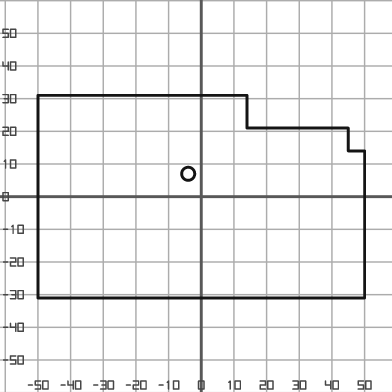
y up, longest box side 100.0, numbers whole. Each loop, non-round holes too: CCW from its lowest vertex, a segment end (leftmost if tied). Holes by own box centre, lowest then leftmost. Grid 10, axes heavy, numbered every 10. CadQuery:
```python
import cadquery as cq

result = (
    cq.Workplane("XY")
    .moveTo(-50.0, -31.0)
    .lineTo(50.0, -31.0)
    .lineTo(50.0, 14.0)
    .lineTo(45.0, 14.0)
    .lineTo(45.0, 21.0)
    .lineTo(14.0, 21.0)
    .lineTo(14.0, 31.0)
    .lineTo(-50.0, 31.0)
    .close()
    .moveTo(-4.0, 7.0)
    .circle(2.0)
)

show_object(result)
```